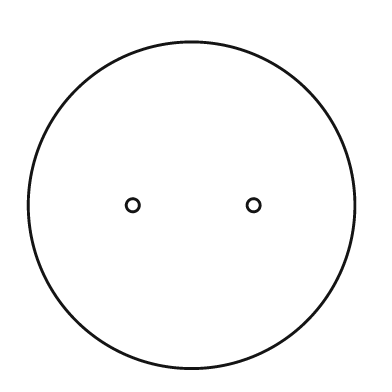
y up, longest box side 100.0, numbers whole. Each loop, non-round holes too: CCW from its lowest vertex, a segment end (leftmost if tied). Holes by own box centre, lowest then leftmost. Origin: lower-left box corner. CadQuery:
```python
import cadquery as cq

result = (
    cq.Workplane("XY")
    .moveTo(50.0, 50.0)
    .circle(50.0)
    .moveTo(32.0, 50.0)
    .circle(2.0)
    .moveTo(69.0, 50.0)
    .circle(2.0)
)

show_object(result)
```